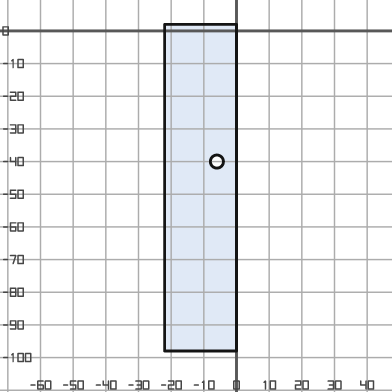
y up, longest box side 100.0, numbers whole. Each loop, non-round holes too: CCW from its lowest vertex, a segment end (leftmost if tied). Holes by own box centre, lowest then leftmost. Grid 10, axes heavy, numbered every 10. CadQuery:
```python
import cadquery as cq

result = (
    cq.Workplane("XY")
    .moveTo(-22.0, -98.0)
    .lineTo(0.0, -98.0)
    .lineTo(0.0, 2.0)
    .lineTo(-22.0, 2.0)
    .close()
    .moveTo(-6.0, -40.0)
    .circle(2.0)
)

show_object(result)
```